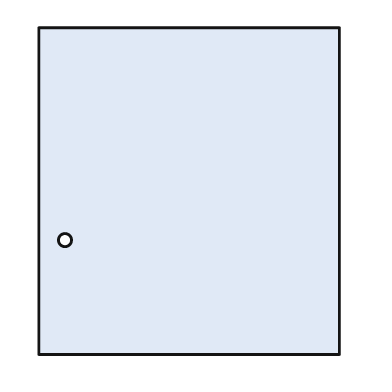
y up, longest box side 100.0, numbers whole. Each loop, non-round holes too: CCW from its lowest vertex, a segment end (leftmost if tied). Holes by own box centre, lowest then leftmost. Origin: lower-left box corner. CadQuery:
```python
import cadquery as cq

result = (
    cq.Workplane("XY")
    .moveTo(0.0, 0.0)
    .lineTo(92.0, 0.0)
    .lineTo(92.0, 100.0)
    .lineTo(0.0, 100.0)
    .close()
    .moveTo(8.0, 35.0)
    .circle(2.0)
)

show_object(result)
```